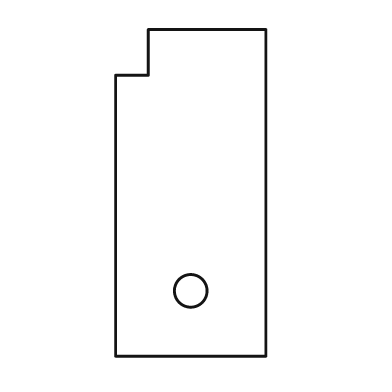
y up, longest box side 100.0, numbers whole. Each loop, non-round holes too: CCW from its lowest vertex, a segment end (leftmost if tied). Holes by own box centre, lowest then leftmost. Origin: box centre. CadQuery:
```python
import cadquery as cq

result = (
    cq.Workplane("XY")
    .moveTo(-23.0, -50.0)
    .lineTo(23.0, -50.0)
    .lineTo(23.0, 50.0)
    .lineTo(-13.0, 50.0)
    .lineTo(-13.0, 36.0)
    .lineTo(-23.0, 36.0)
    .close()
    .moveTo(0.0, -30.0)
    .circle(5.0)
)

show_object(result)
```